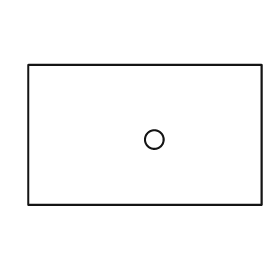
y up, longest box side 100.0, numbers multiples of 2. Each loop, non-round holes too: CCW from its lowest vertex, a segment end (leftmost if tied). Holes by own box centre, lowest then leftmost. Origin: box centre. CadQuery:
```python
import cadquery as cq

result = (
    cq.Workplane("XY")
    .moveTo(-50.0, -30.0)
    .lineTo(50.0, -30.0)
    .lineTo(50.0, 30.0)
    .lineTo(-50.0, 30.0)
    .close()
    .moveTo(4.0, -2.0)
    .circle(4.0)
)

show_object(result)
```